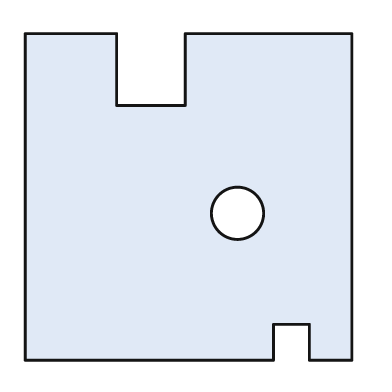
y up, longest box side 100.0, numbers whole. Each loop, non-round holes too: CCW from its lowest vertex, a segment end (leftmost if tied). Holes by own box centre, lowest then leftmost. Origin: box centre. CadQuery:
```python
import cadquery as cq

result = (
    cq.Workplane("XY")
    .moveTo(-50.0, -50.0)
    .lineTo(26.0, -50.0)
    .lineTo(26.0, -39.0)
    .lineTo(37.0, -39.0)
    .lineTo(37.0, -50.0)
    .lineTo(50.0, -50.0)
    .lineTo(50.0, 50.0)
    .lineTo(-1.0, 50.0)
    .lineTo(-1.0, 28.0)
    .lineTo(-22.0, 28.0)
    .lineTo(-22.0, 50.0)
    .lineTo(-50.0, 50.0)
    .close()
    .moveTo(15.0, -5.0)
    .circle(8.0)
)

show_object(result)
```